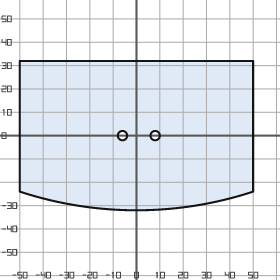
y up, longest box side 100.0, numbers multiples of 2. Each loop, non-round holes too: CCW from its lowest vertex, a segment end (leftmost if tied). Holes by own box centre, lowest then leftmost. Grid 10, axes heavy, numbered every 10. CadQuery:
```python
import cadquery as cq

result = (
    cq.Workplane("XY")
    .moveTo(-50.0, -24.0)
    .threePointArc((0.0, -32.0), (50.0, -24.0))
    .lineTo(50.0, 32.0)
    .lineTo(-50.0, 32.0)
    .close()
    .moveTo(-6.0, 0.0)
    .circle(2.0)
    .moveTo(8.0, 0.0)
    .circle(2.0)
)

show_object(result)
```